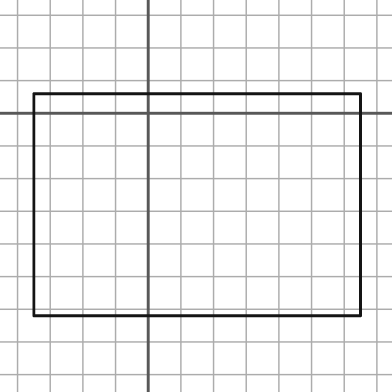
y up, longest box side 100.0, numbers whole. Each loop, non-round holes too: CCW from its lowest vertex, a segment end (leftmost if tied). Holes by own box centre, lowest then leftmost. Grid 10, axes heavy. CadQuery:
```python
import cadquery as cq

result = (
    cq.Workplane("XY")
    .moveTo(-35.0, -62.0)
    .lineTo(65.0, -62.0)
    .lineTo(65.0, 6.0)
    .lineTo(-35.0, 6.0)
    .close()
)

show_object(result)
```